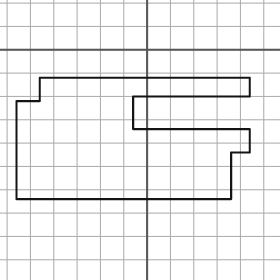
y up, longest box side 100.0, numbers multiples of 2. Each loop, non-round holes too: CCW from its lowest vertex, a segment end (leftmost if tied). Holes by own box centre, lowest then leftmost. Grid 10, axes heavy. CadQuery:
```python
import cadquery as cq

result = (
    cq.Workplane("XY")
    .moveTo(-56.0, -64.0)
    .lineTo(36.0, -64.0)
    .lineTo(36.0, -44.0)
    .lineTo(44.0, -44.0)
    .lineTo(44.0, -34.0)
    .lineTo(-6.0, -34.0)
    .lineTo(-6.0, -20.0)
    .lineTo(44.0, -20.0)
    .lineTo(44.0, -12.0)
    .lineTo(-46.0, -12.0)
    .lineTo(-46.0, -22.0)
    .lineTo(-56.0, -22.0)
    .close()
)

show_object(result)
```